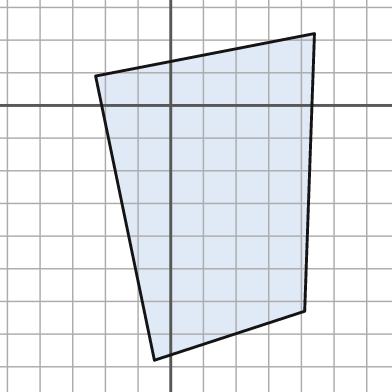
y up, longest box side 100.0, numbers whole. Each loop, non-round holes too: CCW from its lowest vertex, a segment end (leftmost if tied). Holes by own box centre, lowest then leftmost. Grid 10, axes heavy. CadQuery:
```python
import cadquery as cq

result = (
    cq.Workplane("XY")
    .moveTo(-5.0, -78.0)
    .lineTo(41.0, -63.0)
    .lineTo(44.0, 22.0)
    .lineTo(-23.0, 9.0)
    .close()
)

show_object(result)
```